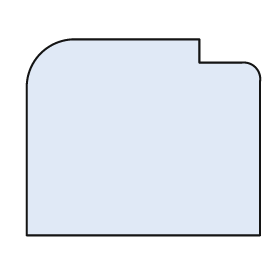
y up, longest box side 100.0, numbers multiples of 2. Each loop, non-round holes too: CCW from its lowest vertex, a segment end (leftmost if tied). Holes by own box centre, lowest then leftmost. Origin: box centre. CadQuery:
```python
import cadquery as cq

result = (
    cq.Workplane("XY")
    .moveTo(-50.0, -42.0)
    .lineTo(50.0, -42.0)
    .lineTo(50.0, 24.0)
    .threePointArc((48.0, 30.0), (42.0, 32.0))
    .lineTo(24.0, 32.0)
    .lineTo(24.0, 42.0)
    .lineTo(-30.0, 42.0)
    .threePointArc((-44.0, 36.0), (-50.0, 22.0))
    .close()
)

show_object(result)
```